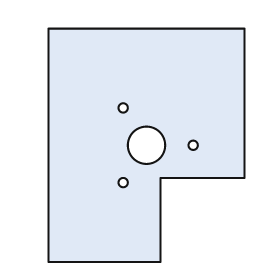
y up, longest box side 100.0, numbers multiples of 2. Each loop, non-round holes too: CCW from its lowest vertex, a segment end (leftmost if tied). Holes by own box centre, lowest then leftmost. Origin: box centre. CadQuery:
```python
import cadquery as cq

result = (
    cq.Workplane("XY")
    .moveTo(-42.0, -50.0)
    .lineTo(6.0, -50.0)
    .lineTo(6.0, -14.0)
    .lineTo(42.0, -14.0)
    .lineTo(42.0, 50.0)
    .lineTo(-42.0, 50.0)
    .close()
    .moveTo(-10.0, -16.0)
    .circle(2.0)
    .moveTo(0.0, 0.0)
    .circle(8.0)
    .moveTo(20.0, 0.0)
    .circle(2.0)
    .moveTo(-10.0, 16.0)
    .circle(2.0)
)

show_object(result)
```